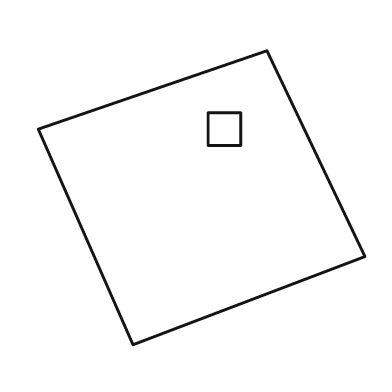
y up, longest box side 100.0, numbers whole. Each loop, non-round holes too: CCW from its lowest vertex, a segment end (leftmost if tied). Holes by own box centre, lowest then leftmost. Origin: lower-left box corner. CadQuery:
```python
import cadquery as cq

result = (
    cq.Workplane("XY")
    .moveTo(29.0, 0.0)
    .lineTo(100.0, 27.0)
    .lineTo(70.0, 90.0)
    .lineTo(0.0, 66.0)
    .close()
    .moveTo(52.0, 61.0)
    .lineTo(62.0, 61.0)
    .lineTo(62.0, 71.0)
    .lineTo(52.0, 71.0)
    .close()
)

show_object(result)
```